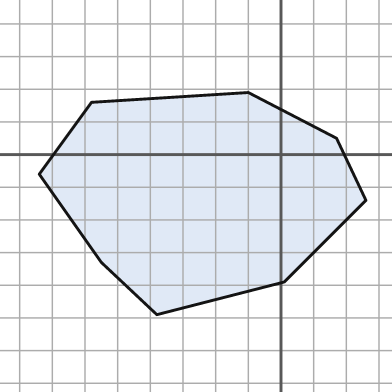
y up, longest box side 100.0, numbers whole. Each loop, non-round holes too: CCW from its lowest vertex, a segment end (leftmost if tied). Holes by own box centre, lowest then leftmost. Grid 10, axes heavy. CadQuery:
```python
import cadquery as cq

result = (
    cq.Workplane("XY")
    .moveTo(-38.0, -49.0)
    .lineTo(1.0, -39.0)
    .lineTo(26.0, -14.0)
    .lineTo(17.0, 5.0)
    .lineTo(-10.0, 19.0)
    .lineTo(-58.0, 16.0)
    .lineTo(-74.0, -6.0)
    .lineTo(-55.0, -33.0)
    .close()
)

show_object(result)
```